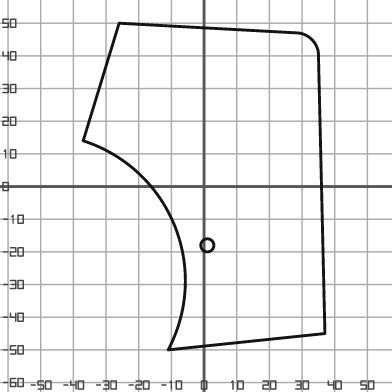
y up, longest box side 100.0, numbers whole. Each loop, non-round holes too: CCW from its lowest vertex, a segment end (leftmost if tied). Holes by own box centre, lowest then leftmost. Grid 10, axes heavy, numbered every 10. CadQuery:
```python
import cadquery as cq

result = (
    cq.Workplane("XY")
    .moveTo(-11.0, -50.0)
    .lineTo(37.0, -45.0)
    .lineTo(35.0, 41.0)
    .threePointArc((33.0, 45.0), (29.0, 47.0))
    .lineTo(-26.0, 50.0)
    .lineTo(-37.0, 14.0)
    .threePointArc((-9.0, -12.0), (-11.0, -50.0))
    .close()
    .moveTo(1.0, -18.0)
    .circle(2.0)
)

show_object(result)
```